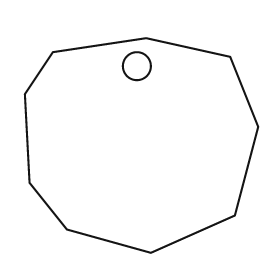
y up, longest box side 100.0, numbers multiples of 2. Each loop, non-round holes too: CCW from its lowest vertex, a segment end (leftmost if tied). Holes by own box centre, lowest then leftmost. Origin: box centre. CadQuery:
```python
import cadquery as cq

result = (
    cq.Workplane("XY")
    .moveTo(4.0, -46.0)
    .lineTo(40.0, -30.0)
    .lineTo(50.0, 8.0)
    .lineTo(38.0, 38.0)
    .lineTo(2.0, 46.0)
    .lineTo(-38.0, 40.0)
    .lineTo(-50.0, 22.0)
    .lineTo(-48.0, -16.0)
    .lineTo(-32.0, -36.0)
    .close()
    .moveTo(-2.0, 34.0)
    .circle(6.0)
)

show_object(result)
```